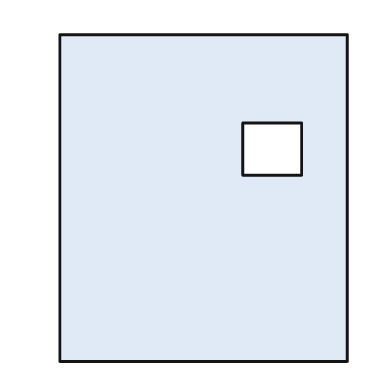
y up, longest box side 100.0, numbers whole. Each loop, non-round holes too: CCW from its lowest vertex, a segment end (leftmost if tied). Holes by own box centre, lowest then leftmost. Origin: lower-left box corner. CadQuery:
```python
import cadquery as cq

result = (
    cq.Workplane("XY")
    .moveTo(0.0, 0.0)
    .lineTo(88.0, 0.0)
    .lineTo(88.0, 100.0)
    .lineTo(0.0, 100.0)
    .close()
    .moveTo(56.0, 57.0)
    .lineTo(74.0, 57.0)
    .lineTo(74.0, 73.0)
    .lineTo(56.0, 73.0)
    .close()
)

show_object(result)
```